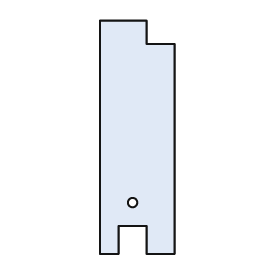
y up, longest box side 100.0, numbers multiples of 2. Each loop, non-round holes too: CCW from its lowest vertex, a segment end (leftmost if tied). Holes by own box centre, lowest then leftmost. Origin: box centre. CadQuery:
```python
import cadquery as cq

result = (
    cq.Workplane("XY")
    .moveTo(-16.0, -50.0)
    .lineTo(-8.0, -50.0)
    .lineTo(-8.0, -38.0)
    .lineTo(4.0, -38.0)
    .lineTo(4.0, -50.0)
    .lineTo(16.0, -50.0)
    .lineTo(16.0, 40.0)
    .lineTo(4.0, 40.0)
    .lineTo(4.0, 50.0)
    .lineTo(-16.0, 50.0)
    .close()
    .moveTo(-2.0, -28.0)
    .circle(2.0)
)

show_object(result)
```